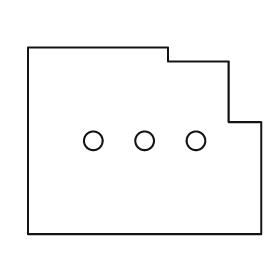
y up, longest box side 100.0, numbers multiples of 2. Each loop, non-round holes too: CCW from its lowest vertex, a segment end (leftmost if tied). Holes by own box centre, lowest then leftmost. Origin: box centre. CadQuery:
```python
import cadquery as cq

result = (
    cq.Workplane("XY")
    .moveTo(-50.0, -40.0)
    .lineTo(50.0, -40.0)
    .lineTo(50.0, 8.0)
    .lineTo(36.0, 8.0)
    .lineTo(36.0, 34.0)
    .lineTo(10.0, 34.0)
    .lineTo(10.0, 40.0)
    .lineTo(-50.0, 40.0)
    .close()
    .moveTo(-22.0, 0.0)
    .circle(4.0)
    .moveTo(0.0, 0.0)
    .circle(4.0)
    .moveTo(22.0, 0.0)
    .circle(4.0)
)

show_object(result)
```